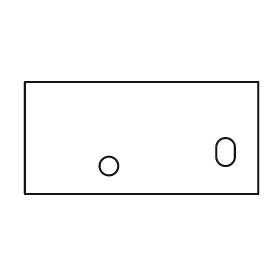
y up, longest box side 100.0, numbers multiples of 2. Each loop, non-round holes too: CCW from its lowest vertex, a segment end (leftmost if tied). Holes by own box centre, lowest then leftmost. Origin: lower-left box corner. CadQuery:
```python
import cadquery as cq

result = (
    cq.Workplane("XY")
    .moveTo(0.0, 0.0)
    .lineTo(100.0, 0.0)
    .lineTo(100.0, 48.0)
    .lineTo(0.0, 48.0)
    .close()
    .moveTo(36.0, 12.0)
    .circle(4.0)
    .moveTo(82.0, 16.0)
    .threePointArc((86.0, 12.0), (90.0, 16.0))
    .lineTo(90.0, 20.0)
    .threePointArc((86.0, 24.0), (82.0, 20.0))
    .close()
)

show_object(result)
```